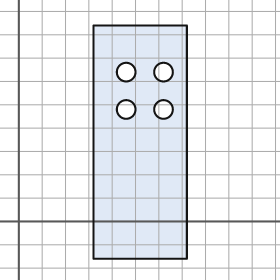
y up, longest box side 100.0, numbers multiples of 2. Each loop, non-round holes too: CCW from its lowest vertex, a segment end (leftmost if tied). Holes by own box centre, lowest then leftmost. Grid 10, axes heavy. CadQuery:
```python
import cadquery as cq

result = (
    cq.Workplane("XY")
    .moveTo(32.0, -16.0)
    .lineTo(72.0, -16.0)
    .lineTo(72.0, 84.0)
    .lineTo(32.0, 84.0)
    .close()
    .moveTo(46.0, 48.0)
    .circle(4.0)
    .moveTo(62.0, 48.0)
    .circle(4.0)
    .moveTo(46.0, 64.0)
    .circle(4.0)
    .moveTo(62.0, 64.0)
    .circle(4.0)
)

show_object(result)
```